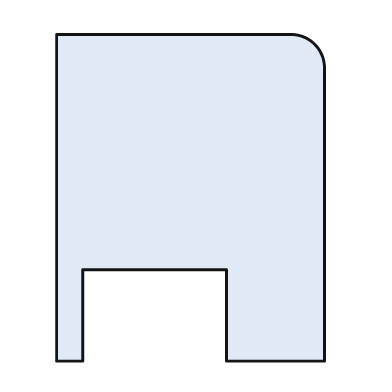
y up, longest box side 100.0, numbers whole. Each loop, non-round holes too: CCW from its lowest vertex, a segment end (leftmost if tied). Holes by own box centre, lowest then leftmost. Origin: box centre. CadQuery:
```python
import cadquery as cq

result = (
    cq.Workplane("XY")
    .moveTo(-41.0, -50.0)
    .lineTo(-33.0, -50.0)
    .lineTo(-33.0, -22.0)
    .lineTo(11.0, -22.0)
    .lineTo(11.0, -50.0)
    .lineTo(41.0, -50.0)
    .lineTo(41.0, 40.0)
    .threePointArc((38.0, 47.0), (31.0, 50.0))
    .lineTo(-41.0, 50.0)
    .close()
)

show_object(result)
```